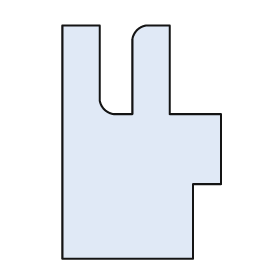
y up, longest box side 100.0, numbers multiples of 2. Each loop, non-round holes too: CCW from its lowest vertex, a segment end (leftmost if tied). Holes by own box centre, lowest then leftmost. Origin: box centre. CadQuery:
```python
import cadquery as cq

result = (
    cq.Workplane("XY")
    .moveTo(-34.0, -50.0)
    .lineTo(22.0, -50.0)
    .lineTo(22.0, -18.0)
    .lineTo(34.0, -18.0)
    .lineTo(34.0, 12.0)
    .lineTo(12.0, 12.0)
    .lineTo(12.0, 50.0)
    .lineTo(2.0, 50.0)
    .threePointArc((-2.0, 48.0), (-4.0, 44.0))
    .lineTo(-4.0, 12.0)
    .lineTo(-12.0, 12.0)
    .threePointArc((-16.0, 14.0), (-18.0, 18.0))
    .lineTo(-18.0, 50.0)
    .lineTo(-34.0, 50.0)
    .close()
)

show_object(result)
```